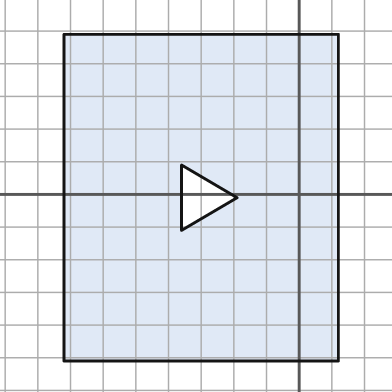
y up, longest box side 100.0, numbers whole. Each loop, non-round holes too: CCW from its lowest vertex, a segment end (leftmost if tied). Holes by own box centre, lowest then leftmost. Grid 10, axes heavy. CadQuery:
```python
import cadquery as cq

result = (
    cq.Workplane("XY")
    .moveTo(-72.0, -51.0)
    .lineTo(12.0, -51.0)
    .lineTo(12.0, 49.0)
    .lineTo(-72.0, 49.0)
    .close()
    .moveTo(-36.0, -11.0)
    .lineTo(-19.0, -1.0)
    .lineTo(-36.0, 9.0)
    .close()
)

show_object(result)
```